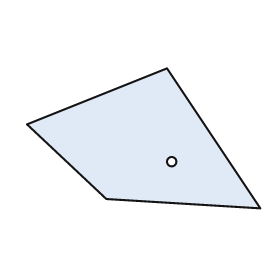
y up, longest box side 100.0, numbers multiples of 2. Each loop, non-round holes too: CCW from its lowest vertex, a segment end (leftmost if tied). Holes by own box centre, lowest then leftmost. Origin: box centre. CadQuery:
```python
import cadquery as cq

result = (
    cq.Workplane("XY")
    .moveTo(50.0, -30.0)
    .lineTo(10.0, 30.0)
    .lineTo(-50.0, 6.0)
    .lineTo(-16.0, -26.0)
    .close()
    .moveTo(12.0, -10.0)
    .circle(2.0)
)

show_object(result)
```